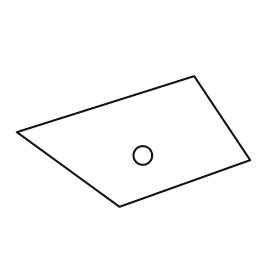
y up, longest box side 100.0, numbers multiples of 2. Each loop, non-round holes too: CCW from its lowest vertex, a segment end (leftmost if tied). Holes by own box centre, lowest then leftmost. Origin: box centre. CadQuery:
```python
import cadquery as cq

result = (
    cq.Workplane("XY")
    .moveTo(-6.0, -28.0)
    .lineTo(50.0, -8.0)
    .lineTo(26.0, 28.0)
    .lineTo(-50.0, 4.0)
    .close()
    .moveTo(4.0, -6.0)
    .circle(4.0)
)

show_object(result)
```